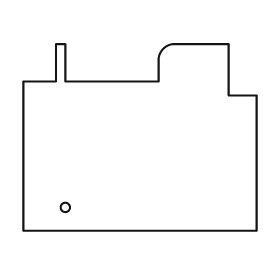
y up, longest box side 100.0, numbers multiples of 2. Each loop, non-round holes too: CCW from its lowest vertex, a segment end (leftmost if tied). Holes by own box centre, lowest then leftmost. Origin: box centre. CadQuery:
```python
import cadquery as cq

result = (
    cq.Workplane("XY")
    .moveTo(-50.0, -40.0)
    .lineTo(50.0, -40.0)
    .lineTo(50.0, 18.0)
    .lineTo(38.0, 18.0)
    .lineTo(38.0, 40.0)
    .lineTo(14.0, 40.0)
    .threePointArc((10.0, 38.0), (8.0, 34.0))
    .lineTo(8.0, 24.0)
    .lineTo(-32.0, 24.0)
    .lineTo(-32.0, 40.0)
    .lineTo(-36.0, 40.0)
    .lineTo(-36.0, 24.0)
    .lineTo(-50.0, 24.0)
    .close()
    .moveTo(-32.0, -30.0)
    .circle(2.0)
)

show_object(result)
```